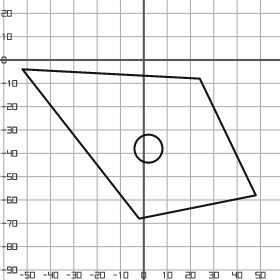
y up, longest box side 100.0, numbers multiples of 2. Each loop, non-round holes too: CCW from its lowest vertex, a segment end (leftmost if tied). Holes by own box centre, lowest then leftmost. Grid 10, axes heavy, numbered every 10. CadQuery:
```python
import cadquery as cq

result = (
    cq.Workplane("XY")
    .moveTo(-2.0, -68.0)
    .lineTo(48.0, -58.0)
    .lineTo(24.0, -8.0)
    .lineTo(-52.0, -4.0)
    .close()
    .moveTo(2.0, -38.0)
    .circle(6.0)
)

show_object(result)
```